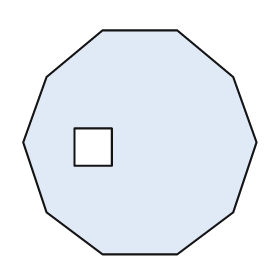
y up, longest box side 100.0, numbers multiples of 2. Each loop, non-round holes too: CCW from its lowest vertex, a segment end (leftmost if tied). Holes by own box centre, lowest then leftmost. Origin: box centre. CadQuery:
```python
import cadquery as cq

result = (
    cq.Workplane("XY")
    .moveTo(-16.0, -48.0)
    .lineTo(16.0, -48.0)
    .lineTo(40.0, -30.0)
    .lineTo(50.0, 0.0)
    .lineTo(40.0, 28.0)
    .lineTo(16.0, 48.0)
    .lineTo(-16.0, 48.0)
    .lineTo(-40.0, 28.0)
    .lineTo(-50.0, 0.0)
    .lineTo(-40.0, -30.0)
    .close()
    .moveTo(-28.0, -10.0)
    .lineTo(-12.0, -10.0)
    .lineTo(-12.0, 6.0)
    .lineTo(-28.0, 6.0)
    .close()
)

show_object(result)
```